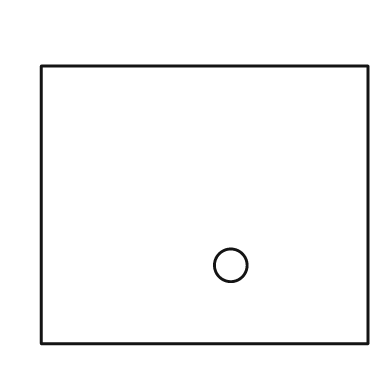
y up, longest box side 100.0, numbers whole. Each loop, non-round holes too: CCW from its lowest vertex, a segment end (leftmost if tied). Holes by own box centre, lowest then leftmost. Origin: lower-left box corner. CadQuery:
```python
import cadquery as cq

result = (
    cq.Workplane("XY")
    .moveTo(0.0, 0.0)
    .lineTo(100.0, 0.0)
    .lineTo(100.0, 85.0)
    .lineTo(0.0, 85.0)
    .close()
    .moveTo(58.0, 24.0)
    .circle(5.0)
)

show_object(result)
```